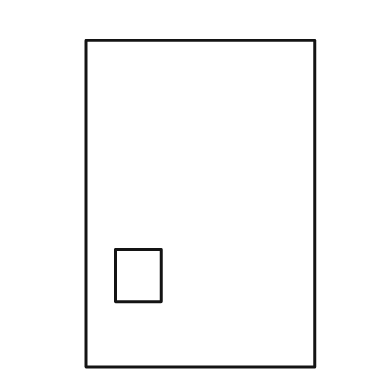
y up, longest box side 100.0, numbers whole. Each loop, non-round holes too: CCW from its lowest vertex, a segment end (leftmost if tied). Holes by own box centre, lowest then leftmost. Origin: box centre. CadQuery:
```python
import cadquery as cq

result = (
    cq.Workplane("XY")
    .moveTo(-35.0, -50.0)
    .lineTo(35.0, -50.0)
    .lineTo(35.0, 50.0)
    .lineTo(-35.0, 50.0)
    .close()
    .moveTo(-26.0, -30.0)
    .lineTo(-12.0, -30.0)
    .lineTo(-12.0, -14.0)
    .lineTo(-26.0, -14.0)
    .close()
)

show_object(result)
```